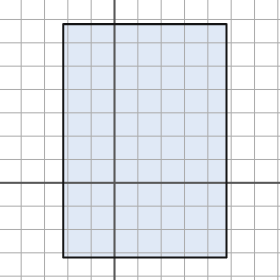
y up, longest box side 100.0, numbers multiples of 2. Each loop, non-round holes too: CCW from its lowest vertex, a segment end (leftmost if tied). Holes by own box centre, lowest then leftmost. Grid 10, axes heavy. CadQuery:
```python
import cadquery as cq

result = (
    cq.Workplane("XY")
    .moveTo(-22.0, -32.0)
    .lineTo(48.0, -32.0)
    .lineTo(48.0, 68.0)
    .lineTo(-22.0, 68.0)
    .close()
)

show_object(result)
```